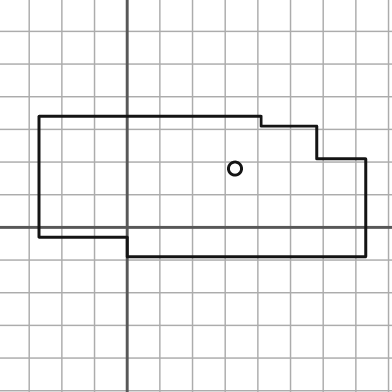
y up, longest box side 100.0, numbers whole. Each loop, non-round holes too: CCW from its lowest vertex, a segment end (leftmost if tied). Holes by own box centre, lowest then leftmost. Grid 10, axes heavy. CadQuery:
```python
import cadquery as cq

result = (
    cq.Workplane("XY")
    .moveTo(0.0, -9.0)
    .lineTo(73.0, -9.0)
    .lineTo(73.0, 21.0)
    .lineTo(58.0, 21.0)
    .lineTo(58.0, 31.0)
    .lineTo(41.0, 31.0)
    .lineTo(41.0, 34.0)
    .lineTo(-27.0, 34.0)
    .lineTo(-27.0, -3.0)
    .lineTo(0.0, -3.0)
    .close()
    .moveTo(33.0, 18.0)
    .circle(2.0)
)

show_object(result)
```